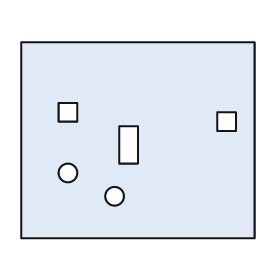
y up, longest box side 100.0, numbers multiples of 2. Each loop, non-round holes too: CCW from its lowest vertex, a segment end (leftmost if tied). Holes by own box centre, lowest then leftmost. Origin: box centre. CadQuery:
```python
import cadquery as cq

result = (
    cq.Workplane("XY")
    .moveTo(-50.0, -42.0)
    .lineTo(50.0, -42.0)
    .lineTo(50.0, 42.0)
    .lineTo(-50.0, 42.0)
    .close()
    .moveTo(-10.0, -24.0)
    .circle(4.0)
    .moveTo(-30.0, -14.0)
    .circle(4.0)
    .moveTo(-8.0, -10.0)
    .lineTo(0.0, -10.0)
    .lineTo(0.0, 6.0)
    .lineTo(-8.0, 6.0)
    .close()
    .moveTo(34.0, 4.0)
    .lineTo(42.0, 4.0)
    .lineTo(42.0, 12.0)
    .lineTo(34.0, 12.0)
    .close()
    .moveTo(-34.0, 8.0)
    .lineTo(-26.0, 8.0)
    .lineTo(-26.0, 16.0)
    .lineTo(-34.0, 16.0)
    .close()
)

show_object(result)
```